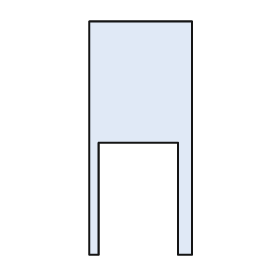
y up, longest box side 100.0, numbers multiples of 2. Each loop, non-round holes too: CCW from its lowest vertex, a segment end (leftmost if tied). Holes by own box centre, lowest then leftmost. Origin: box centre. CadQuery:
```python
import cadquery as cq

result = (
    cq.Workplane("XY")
    .moveTo(-22.0, -50.0)
    .lineTo(-18.0, -50.0)
    .lineTo(-18.0, -2.0)
    .lineTo(16.0, -2.0)
    .lineTo(16.0, -50.0)
    .lineTo(22.0, -50.0)
    .lineTo(22.0, 50.0)
    .lineTo(-22.0, 50.0)
    .close()
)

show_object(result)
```